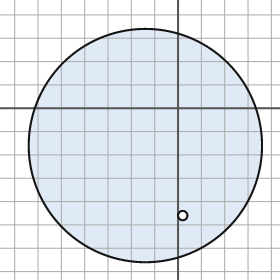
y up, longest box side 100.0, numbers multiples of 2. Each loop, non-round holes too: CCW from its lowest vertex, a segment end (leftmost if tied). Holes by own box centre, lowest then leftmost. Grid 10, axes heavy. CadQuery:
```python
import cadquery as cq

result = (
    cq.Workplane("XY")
    .moveTo(-14.0, -16.0)
    .circle(50.0)
    .moveTo(2.0, -46.0)
    .circle(2.0)
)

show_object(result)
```